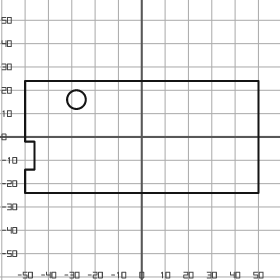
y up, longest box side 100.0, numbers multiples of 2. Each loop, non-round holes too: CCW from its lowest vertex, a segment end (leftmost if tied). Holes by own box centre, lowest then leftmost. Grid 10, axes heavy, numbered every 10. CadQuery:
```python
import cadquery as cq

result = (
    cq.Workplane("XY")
    .moveTo(-50.0, -24.0)
    .lineTo(50.0, -24.0)
    .lineTo(50.0, 24.0)
    .lineTo(-50.0, 24.0)
    .lineTo(-50.0, -2.0)
    .lineTo(-46.0, -2.0)
    .lineTo(-46.0, -14.0)
    .lineTo(-50.0, -14.0)
    .close()
    .moveTo(-28.0, 16.0)
    .circle(4.0)
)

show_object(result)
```